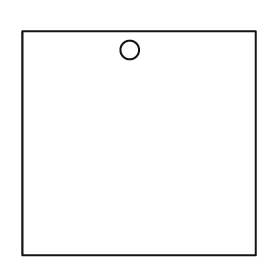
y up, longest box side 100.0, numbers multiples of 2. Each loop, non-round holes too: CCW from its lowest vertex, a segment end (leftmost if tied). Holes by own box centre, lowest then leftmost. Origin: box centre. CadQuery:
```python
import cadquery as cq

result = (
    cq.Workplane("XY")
    .moveTo(-50.0, -48.0)
    .lineTo(50.0, -48.0)
    .lineTo(50.0, 48.0)
    .lineTo(-50.0, 48.0)
    .close()
    .moveTo(-4.0, 40.0)
    .circle(4.0)
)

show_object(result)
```